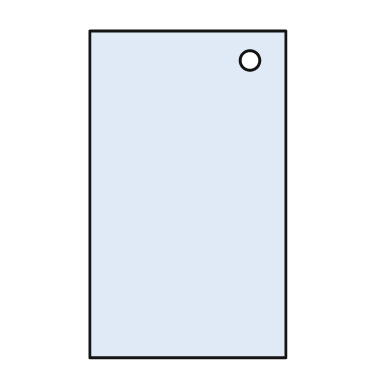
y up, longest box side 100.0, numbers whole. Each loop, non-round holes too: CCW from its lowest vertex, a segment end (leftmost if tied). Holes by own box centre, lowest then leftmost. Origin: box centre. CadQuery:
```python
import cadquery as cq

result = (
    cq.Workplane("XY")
    .moveTo(-30.0, -50.0)
    .lineTo(30.0, -50.0)
    .lineTo(30.0, 50.0)
    .lineTo(-30.0, 50.0)
    .close()
    .moveTo(19.0, 41.0)
    .circle(3.0)
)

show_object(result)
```